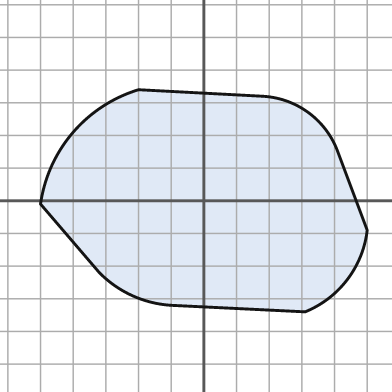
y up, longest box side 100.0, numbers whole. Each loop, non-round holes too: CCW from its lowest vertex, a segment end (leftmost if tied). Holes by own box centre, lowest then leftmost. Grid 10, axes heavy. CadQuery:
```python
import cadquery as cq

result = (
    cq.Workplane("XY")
    .moveTo(31.0, -34.0)
    .threePointArc((44.0, -24.0), (50.0, -9.0))
    .lineTo(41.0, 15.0)
    .threePointArc((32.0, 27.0), (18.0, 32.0))
    .lineTo(-20.0, 34.0)
    .threePointArc((-40.0, 21.0), (-50.0, -1.0))
    .lineTo(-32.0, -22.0)
    .threePointArc((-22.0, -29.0), (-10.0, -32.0))
    .close()
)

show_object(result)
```